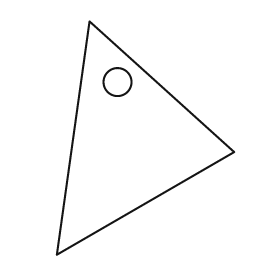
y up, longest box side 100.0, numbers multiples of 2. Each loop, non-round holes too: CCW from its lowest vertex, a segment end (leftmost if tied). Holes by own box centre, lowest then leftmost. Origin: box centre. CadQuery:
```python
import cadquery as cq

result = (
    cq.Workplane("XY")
    .moveTo(-38.0, -50.0)
    .lineTo(38.0, -6.0)
    .lineTo(-24.0, 50.0)
    .close()
    .moveTo(-12.0, 24.0)
    .circle(6.0)
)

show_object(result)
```